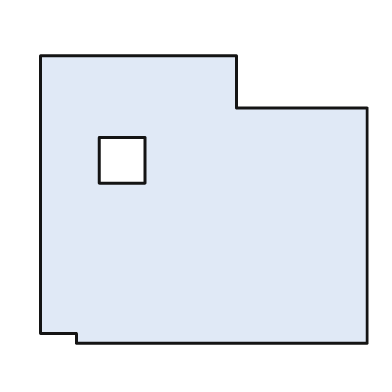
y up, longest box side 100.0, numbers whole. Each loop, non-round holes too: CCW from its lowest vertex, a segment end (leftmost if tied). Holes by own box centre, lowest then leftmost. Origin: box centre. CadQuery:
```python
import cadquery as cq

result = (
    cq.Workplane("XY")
    .moveTo(-39.0, -44.0)
    .lineTo(50.0, -44.0)
    .lineTo(50.0, 28.0)
    .lineTo(10.0, 28.0)
    .lineTo(10.0, 44.0)
    .lineTo(-50.0, 44.0)
    .lineTo(-50.0, -41.0)
    .lineTo(-39.0, -41.0)
    .close()
    .moveTo(-32.0, 5.0)
    .lineTo(-18.0, 5.0)
    .lineTo(-18.0, 19.0)
    .lineTo(-32.0, 19.0)
    .close()
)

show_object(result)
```